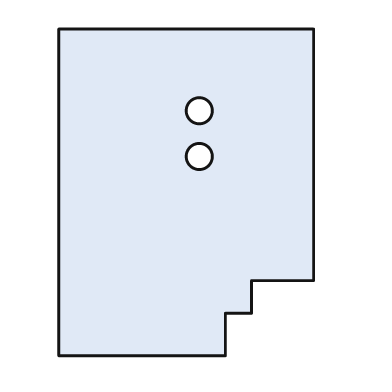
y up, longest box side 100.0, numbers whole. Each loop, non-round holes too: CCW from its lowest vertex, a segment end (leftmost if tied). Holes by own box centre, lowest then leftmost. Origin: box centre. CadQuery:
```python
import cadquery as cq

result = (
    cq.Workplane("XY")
    .moveTo(-39.0, -50.0)
    .lineTo(12.0, -50.0)
    .lineTo(12.0, -37.0)
    .lineTo(20.0, -37.0)
    .lineTo(20.0, -27.0)
    .lineTo(39.0, -27.0)
    .lineTo(39.0, 50.0)
    .lineTo(-39.0, 50.0)
    .close()
    .moveTo(4.0, 11.0)
    .circle(4.0)
    .moveTo(4.0, 25.0)
    .circle(4.0)
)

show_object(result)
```